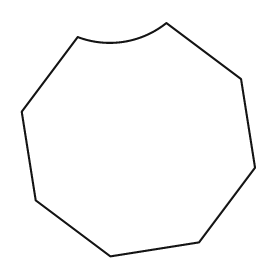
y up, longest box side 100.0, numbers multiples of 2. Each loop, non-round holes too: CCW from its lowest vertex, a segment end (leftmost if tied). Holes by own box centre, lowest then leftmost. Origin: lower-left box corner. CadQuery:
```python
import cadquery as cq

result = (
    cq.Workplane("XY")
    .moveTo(38.0, 0.0)
    .lineTo(76.0, 6.0)
    .lineTo(100.0, 38.0)
    .lineTo(94.0, 76.0)
    .lineTo(62.0, 100.0)
    .threePointArc((44.0, 92.0), (24.0, 94.0))
    .lineTo(0.0, 62.0)
    .lineTo(6.0, 24.0)
    .close()
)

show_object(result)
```